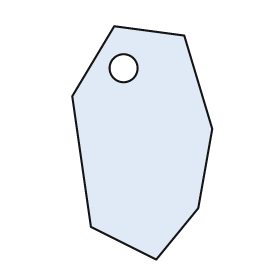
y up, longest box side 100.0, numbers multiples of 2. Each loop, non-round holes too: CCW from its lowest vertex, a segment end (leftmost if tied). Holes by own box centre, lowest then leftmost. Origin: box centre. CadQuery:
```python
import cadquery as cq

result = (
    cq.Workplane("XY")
    .moveTo(6.0, -50.0)
    .lineTo(24.0, -28.0)
    .lineTo(30.0, 6.0)
    .lineTo(18.0, 46.0)
    .lineTo(-12.0, 50.0)
    .lineTo(-30.0, 20.0)
    .lineTo(-22.0, -36.0)
    .close()
    .moveTo(-8.0, 32.0)
    .circle(6.0)
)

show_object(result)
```